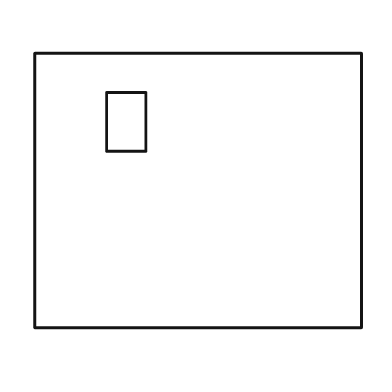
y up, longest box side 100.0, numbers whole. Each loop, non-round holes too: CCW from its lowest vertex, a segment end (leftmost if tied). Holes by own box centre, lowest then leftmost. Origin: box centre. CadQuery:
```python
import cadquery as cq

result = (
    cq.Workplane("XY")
    .moveTo(-50.0, -42.0)
    .lineTo(50.0, -42.0)
    .lineTo(50.0, 42.0)
    .lineTo(-50.0, 42.0)
    .close()
    .moveTo(-28.0, 12.0)
    .lineTo(-16.0, 12.0)
    .lineTo(-16.0, 30.0)
    .lineTo(-28.0, 30.0)
    .close()
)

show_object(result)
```